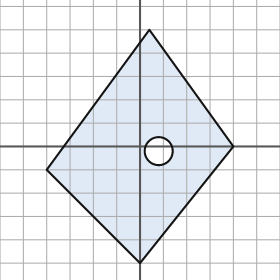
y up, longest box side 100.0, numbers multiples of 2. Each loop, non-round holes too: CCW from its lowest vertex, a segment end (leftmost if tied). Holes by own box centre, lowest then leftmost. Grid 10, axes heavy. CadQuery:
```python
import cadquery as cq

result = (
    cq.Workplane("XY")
    .moveTo(0.0, -50.0)
    .lineTo(40.0, 0.0)
    .lineTo(4.0, 50.0)
    .lineTo(-40.0, -10.0)
    .close()
    .moveTo(8.0, -2.0)
    .circle(6.0)
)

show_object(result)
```